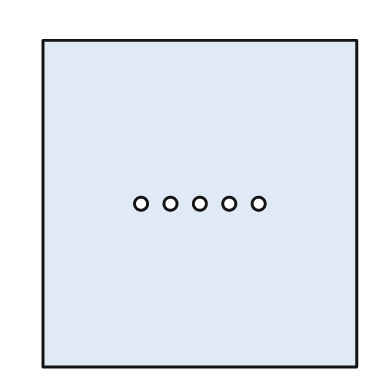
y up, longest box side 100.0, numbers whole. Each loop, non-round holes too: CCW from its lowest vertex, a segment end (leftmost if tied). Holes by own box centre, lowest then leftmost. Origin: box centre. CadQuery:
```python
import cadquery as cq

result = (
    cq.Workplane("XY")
    .moveTo(-48.0, -50.0)
    .lineTo(48.0, -50.0)
    .lineTo(48.0, 50.0)
    .lineTo(-48.0, 50.0)
    .close()
    .moveTo(-18.0, 0.0)
    .circle(2.0)
    .moveTo(-9.0, 0.0)
    .circle(2.0)
    .moveTo(0.0, 0.0)
    .circle(2.0)
    .moveTo(9.0, 0.0)
    .circle(2.0)
    .moveTo(18.0, 0.0)
    .circle(2.0)
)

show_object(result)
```